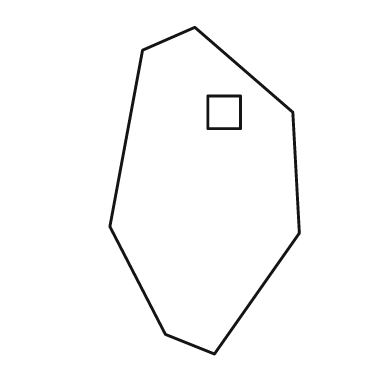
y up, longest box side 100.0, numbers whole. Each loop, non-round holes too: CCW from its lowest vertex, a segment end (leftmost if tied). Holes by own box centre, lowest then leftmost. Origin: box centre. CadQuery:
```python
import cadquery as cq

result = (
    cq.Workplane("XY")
    .moveTo(3.0, -50.0)
    .lineTo(29.0, -13.0)
    .lineTo(27.0, 24.0)
    .lineTo(-3.0, 50.0)
    .lineTo(-19.0, 43.0)
    .lineTo(-29.0, -11.0)
    .lineTo(-12.0, -44.0)
    .close()
    .moveTo(1.0, 19.0)
    .lineTo(11.0, 19.0)
    .lineTo(11.0, 29.0)
    .lineTo(1.0, 29.0)
    .close()
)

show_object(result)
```